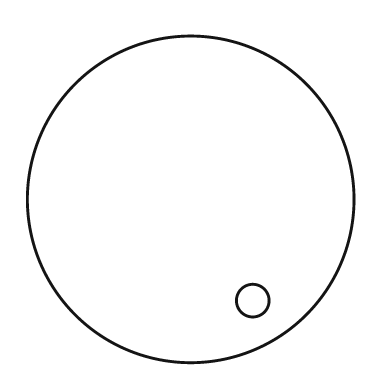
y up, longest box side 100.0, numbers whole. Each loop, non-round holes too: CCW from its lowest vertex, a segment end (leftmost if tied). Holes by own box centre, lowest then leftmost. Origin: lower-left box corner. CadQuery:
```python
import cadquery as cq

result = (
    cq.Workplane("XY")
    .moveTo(50.0, 50.0)
    .circle(50.0)
    .moveTo(69.0, 19.0)
    .circle(5.0)
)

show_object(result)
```